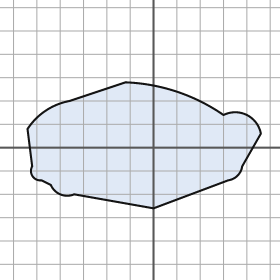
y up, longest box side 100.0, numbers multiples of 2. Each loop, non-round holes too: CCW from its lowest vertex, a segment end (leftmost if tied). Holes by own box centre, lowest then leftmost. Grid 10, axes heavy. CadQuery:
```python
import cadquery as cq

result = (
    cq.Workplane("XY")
    .moveTo(0.0, -26.0)
    .lineTo(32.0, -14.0)
    .threePointArc((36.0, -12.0), (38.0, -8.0))
    .lineTo(46.0, 6.0)
    .threePointArc((40.0, 14.0), (30.0, 14.0))
    .threePointArc((10.0, 24.0), (-12.0, 28.0))
    .lineTo(-36.0, 20.0)
    .threePointArc((-46.0, 16.0), (-54.0, 8.0))
    .lineTo(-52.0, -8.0)
    .threePointArc((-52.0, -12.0), (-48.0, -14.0))
    .lineTo(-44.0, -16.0)
    .threePointArc((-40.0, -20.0), (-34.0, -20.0))
    .close()
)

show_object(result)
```